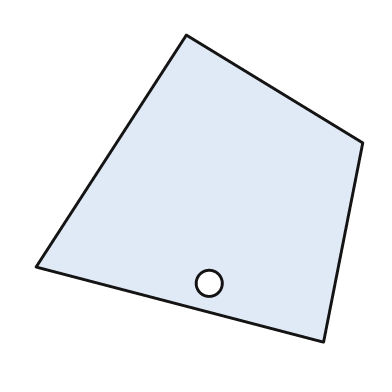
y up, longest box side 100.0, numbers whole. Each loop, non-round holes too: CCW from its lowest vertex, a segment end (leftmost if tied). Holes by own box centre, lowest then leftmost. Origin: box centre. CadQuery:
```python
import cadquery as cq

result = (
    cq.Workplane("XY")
    .moveTo(38.0, -47.0)
    .lineTo(50.0, 14.0)
    .lineTo(-4.0, 47.0)
    .lineTo(-50.0, -24.0)
    .close()
    .moveTo(3.0, -29.0)
    .circle(4.0)
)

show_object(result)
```